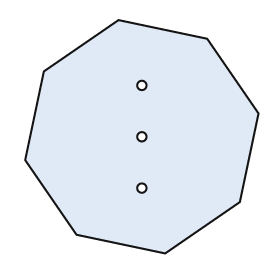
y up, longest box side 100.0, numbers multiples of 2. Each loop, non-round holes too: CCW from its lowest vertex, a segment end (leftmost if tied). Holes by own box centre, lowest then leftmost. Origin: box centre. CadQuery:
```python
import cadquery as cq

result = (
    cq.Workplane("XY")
    .moveTo(10.0, -50.0)
    .lineTo(42.0, -28.0)
    .lineTo(50.0, 10.0)
    .lineTo(28.0, 42.0)
    .lineTo(-10.0, 50.0)
    .lineTo(-42.0, 28.0)
    .lineTo(-50.0, -10.0)
    .lineTo(-28.0, -42.0)
    .close()
    .moveTo(0.0, -22.0)
    .circle(2.0)
    .moveTo(0.0, 0.0)
    .circle(2.0)
    .moveTo(0.0, 22.0)
    .circle(2.0)
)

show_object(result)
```